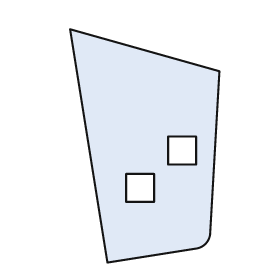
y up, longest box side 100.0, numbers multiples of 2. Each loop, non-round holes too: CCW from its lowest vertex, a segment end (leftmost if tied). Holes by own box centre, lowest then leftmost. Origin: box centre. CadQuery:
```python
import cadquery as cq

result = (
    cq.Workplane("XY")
    .moveTo(-16.0, -50.0)
    .lineTo(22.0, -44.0)
    .threePointArc((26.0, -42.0), (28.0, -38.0))
    .lineTo(32.0, 32.0)
    .lineTo(-32.0, 50.0)
    .close()
    .moveTo(-8.0, -24.0)
    .lineTo(4.0, -24.0)
    .lineTo(4.0, -12.0)
    .lineTo(-8.0, -12.0)
    .close()
    .moveTo(10.0, -8.0)
    .lineTo(22.0, -8.0)
    .lineTo(22.0, 4.0)
    .lineTo(10.0, 4.0)
    .close()
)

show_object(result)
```